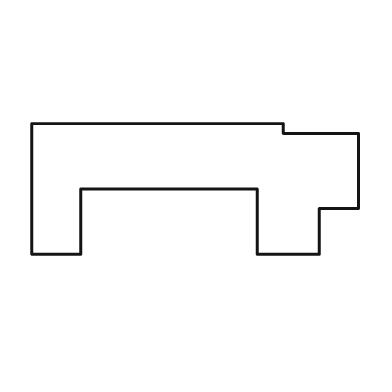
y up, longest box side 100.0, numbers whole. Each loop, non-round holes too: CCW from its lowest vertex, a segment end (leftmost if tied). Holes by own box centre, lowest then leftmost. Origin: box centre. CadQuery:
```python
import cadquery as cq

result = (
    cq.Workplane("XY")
    .moveTo(-50.0, -20.0)
    .lineTo(-35.0, -20.0)
    .lineTo(-35.0, 0.0)
    .lineTo(19.0, 0.0)
    .lineTo(19.0, -20.0)
    .lineTo(38.0, -20.0)
    .lineTo(38.0, -6.0)
    .lineTo(50.0, -6.0)
    .lineTo(50.0, 17.0)
    .lineTo(27.0, 17.0)
    .lineTo(27.0, 20.0)
    .lineTo(-50.0, 20.0)
    .close()
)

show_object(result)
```